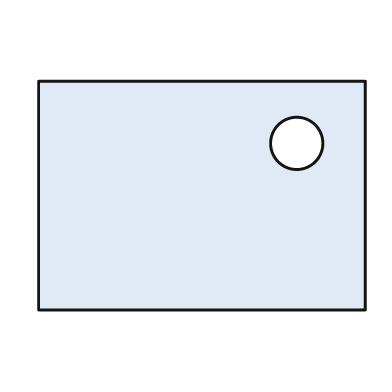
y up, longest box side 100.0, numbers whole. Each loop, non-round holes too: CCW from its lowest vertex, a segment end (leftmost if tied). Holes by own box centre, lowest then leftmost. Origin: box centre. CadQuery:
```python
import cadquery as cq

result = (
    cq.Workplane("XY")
    .moveTo(-50.0, -35.0)
    .lineTo(50.0, -35.0)
    .lineTo(50.0, 35.0)
    .lineTo(-50.0, 35.0)
    .close()
    .moveTo(29.0, 16.0)
    .circle(8.0)
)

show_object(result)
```